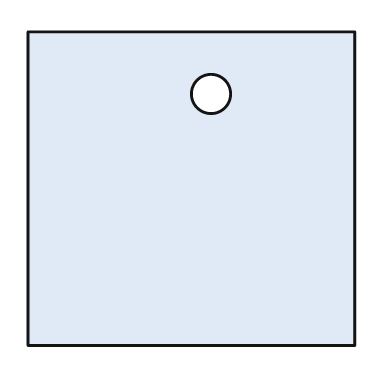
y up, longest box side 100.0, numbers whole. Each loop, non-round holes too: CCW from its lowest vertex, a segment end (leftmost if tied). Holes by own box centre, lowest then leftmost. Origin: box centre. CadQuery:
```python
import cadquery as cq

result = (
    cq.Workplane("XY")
    .moveTo(-50.0, -48.0)
    .lineTo(50.0, -48.0)
    .lineTo(50.0, 48.0)
    .lineTo(-50.0, 48.0)
    .close()
    .moveTo(6.0, 29.0)
    .circle(6.0)
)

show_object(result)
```